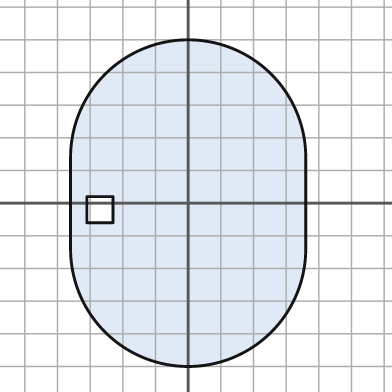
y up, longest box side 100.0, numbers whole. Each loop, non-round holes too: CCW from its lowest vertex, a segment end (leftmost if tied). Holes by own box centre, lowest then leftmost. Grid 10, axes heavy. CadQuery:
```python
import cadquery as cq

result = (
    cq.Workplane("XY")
    .moveTo(-36.0, -14.0)
    .threePointArc((0.0, -50.0), (36.0, -14.0))
    .lineTo(36.0, 14.0)
    .threePointArc((0.0, 50.0), (-36.0, 14.0))
    .close()
    .moveTo(-31.0, -6.0)
    .lineTo(-23.0, -6.0)
    .lineTo(-23.0, 2.0)
    .lineTo(-31.0, 2.0)
    .close()
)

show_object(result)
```